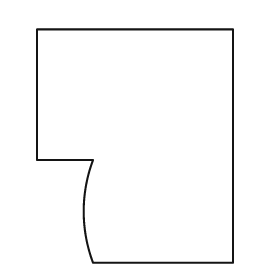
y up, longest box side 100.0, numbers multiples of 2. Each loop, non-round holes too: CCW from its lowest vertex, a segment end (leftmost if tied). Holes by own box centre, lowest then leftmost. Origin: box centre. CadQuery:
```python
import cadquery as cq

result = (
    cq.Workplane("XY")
    .moveTo(-18.0, -50.0)
    .lineTo(42.0, -50.0)
    .lineTo(42.0, 50.0)
    .lineTo(-42.0, 50.0)
    .lineTo(-42.0, -6.0)
    .lineTo(-18.0, -6.0)
    .threePointArc((-22.0, -28.0), (-18.0, -50.0))
    .close()
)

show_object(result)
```